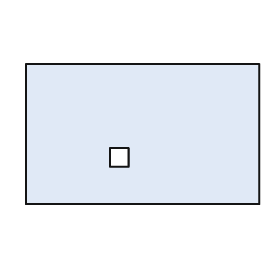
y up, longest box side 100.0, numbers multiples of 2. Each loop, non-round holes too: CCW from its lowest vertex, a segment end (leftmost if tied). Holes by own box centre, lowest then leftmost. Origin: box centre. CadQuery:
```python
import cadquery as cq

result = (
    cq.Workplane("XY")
    .moveTo(-50.0, -30.0)
    .lineTo(50.0, -30.0)
    .lineTo(50.0, 30.0)
    .lineTo(-50.0, 30.0)
    .close()
    .moveTo(-14.0, -14.0)
    .lineTo(-6.0, -14.0)
    .lineTo(-6.0, -6.0)
    .lineTo(-14.0, -6.0)
    .close()
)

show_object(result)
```